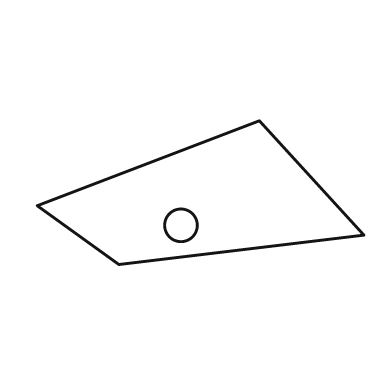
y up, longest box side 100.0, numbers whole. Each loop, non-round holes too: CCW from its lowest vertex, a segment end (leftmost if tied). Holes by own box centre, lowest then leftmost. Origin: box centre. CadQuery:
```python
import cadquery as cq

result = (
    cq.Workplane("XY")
    .moveTo(-25.0, -22.0)
    .lineTo(50.0, -13.0)
    .lineTo(18.0, 22.0)
    .lineTo(-50.0, -4.0)
    .close()
    .moveTo(-6.0, -10.0)
    .circle(5.0)
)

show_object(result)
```